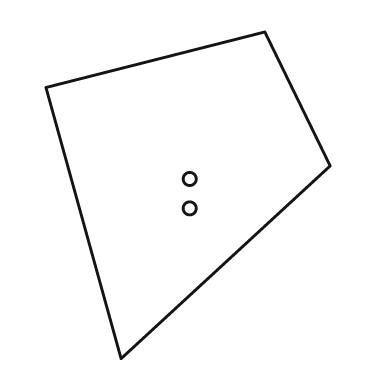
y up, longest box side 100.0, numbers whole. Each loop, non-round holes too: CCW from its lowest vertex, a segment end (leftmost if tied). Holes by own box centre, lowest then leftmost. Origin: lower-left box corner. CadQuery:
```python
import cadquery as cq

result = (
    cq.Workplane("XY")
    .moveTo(23.0, 0.0)
    .lineTo(87.0, 59.0)
    .lineTo(67.0, 100.0)
    .lineTo(0.0, 83.0)
    .close()
    .moveTo(44.0, 46.0)
    .circle(2.0)
    .moveTo(44.0, 55.0)
    .circle(2.0)
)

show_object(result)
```